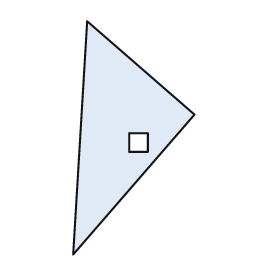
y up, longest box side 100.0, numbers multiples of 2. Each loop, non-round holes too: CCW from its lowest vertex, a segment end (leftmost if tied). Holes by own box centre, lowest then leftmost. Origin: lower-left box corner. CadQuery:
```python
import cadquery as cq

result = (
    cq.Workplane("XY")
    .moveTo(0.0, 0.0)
    .lineTo(52.0, 60.0)
    .lineTo(6.0, 100.0)
    .close()
    .moveTo(24.0, 44.0)
    .lineTo(32.0, 44.0)
    .lineTo(32.0, 52.0)
    .lineTo(24.0, 52.0)
    .close()
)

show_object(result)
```